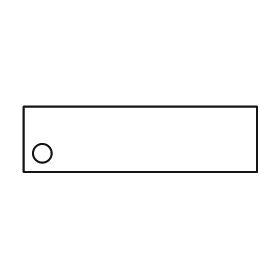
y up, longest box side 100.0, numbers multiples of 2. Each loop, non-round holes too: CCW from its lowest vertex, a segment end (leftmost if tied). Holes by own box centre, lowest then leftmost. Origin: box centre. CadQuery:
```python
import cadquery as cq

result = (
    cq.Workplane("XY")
    .moveTo(-50.0, -14.0)
    .lineTo(50.0, -14.0)
    .lineTo(50.0, 14.0)
    .lineTo(-50.0, 14.0)
    .close()
    .moveTo(-42.0, -6.0)
    .circle(4.0)
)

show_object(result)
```